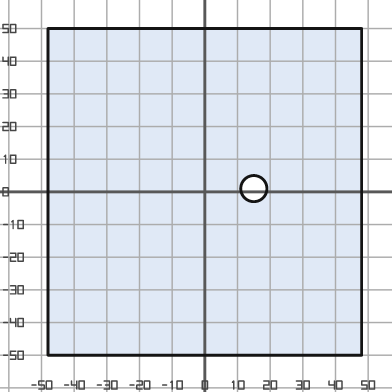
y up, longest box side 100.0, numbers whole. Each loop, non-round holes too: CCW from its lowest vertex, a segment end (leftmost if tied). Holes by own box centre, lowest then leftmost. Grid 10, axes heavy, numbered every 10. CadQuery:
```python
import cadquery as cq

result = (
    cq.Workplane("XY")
    .moveTo(-48.0, -50.0)
    .lineTo(48.0, -50.0)
    .lineTo(48.0, 50.0)
    .lineTo(-48.0, 50.0)
    .close()
    .moveTo(15.0, 1.0)
    .circle(4.0)
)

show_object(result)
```